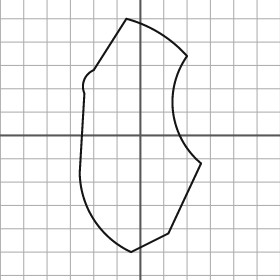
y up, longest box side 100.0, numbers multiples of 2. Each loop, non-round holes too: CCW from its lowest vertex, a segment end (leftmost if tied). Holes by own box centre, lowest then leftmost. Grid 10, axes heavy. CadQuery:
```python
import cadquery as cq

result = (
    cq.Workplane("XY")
    .moveTo(-4.0, -50.0)
    .lineTo(12.0, -42.0)
    .lineTo(26.0, -12.0)
    .threePointArc((14.0, 10.0), (20.0, 34.0))
    .threePointArc((8.0, 44.0), (-6.0, 50.0))
    .lineTo(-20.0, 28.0)
    .threePointArc((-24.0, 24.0), (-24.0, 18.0))
    .lineTo(-26.0, -16.0)
    .threePointArc((-20.0, -36.0), (-4.0, -50.0))
    .close()
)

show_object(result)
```